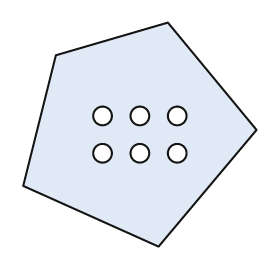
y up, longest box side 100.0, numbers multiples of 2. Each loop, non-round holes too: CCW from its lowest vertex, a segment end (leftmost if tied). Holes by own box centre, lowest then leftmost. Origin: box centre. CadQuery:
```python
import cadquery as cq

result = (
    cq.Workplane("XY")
    .moveTo(8.0, -48.0)
    .lineTo(50.0, 2.0)
    .lineTo(12.0, 48.0)
    .lineTo(-36.0, 34.0)
    .lineTo(-50.0, -22.0)
    .close()
    .moveTo(-16.0, -8.0)
    .circle(4.0)
    .moveTo(0.0, -8.0)
    .circle(4.0)
    .moveTo(16.0, -8.0)
    .circle(4.0)
    .moveTo(-16.0, 8.0)
    .circle(4.0)
    .moveTo(0.0, 8.0)
    .circle(4.0)
    .moveTo(16.0, 8.0)
    .circle(4.0)
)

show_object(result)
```